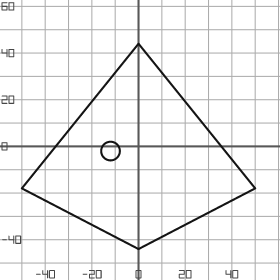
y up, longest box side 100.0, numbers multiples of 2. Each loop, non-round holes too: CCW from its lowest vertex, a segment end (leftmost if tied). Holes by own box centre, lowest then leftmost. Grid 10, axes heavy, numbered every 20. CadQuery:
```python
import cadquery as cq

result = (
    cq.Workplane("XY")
    .moveTo(0.0, -44.0)
    .lineTo(50.0, -18.0)
    .lineTo(0.0, 44.0)
    .lineTo(-50.0, -18.0)
    .close()
    .moveTo(-12.0, -2.0)
    .circle(4.0)
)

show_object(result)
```